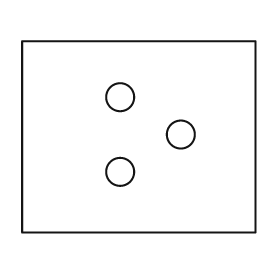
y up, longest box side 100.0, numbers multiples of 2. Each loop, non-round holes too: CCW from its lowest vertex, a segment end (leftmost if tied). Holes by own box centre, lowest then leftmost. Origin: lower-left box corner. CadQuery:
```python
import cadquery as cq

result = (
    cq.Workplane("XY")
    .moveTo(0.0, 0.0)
    .lineTo(100.0, 0.0)
    .lineTo(100.0, 82.0)
    .lineTo(0.0, 82.0)
    .close()
    .moveTo(42.0, 26.0)
    .circle(6.0)
    .moveTo(68.0, 42.0)
    .circle(6.0)
    .moveTo(42.0, 58.0)
    .circle(6.0)
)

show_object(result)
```